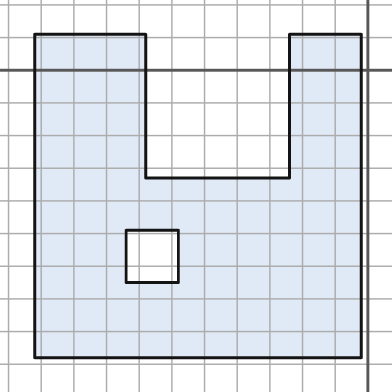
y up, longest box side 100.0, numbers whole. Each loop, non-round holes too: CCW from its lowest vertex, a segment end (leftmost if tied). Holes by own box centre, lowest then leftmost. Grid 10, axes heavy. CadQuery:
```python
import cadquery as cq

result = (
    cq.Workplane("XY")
    .moveTo(-102.0, -88.0)
    .lineTo(-2.0, -88.0)
    .lineTo(-2.0, 11.0)
    .lineTo(-24.0, 11.0)
    .lineTo(-24.0, -33.0)
    .lineTo(-68.0, -33.0)
    .lineTo(-68.0, 11.0)
    .lineTo(-102.0, 11.0)
    .close()
    .moveTo(-74.0, -65.0)
    .lineTo(-58.0, -65.0)
    .lineTo(-58.0, -49.0)
    .lineTo(-74.0, -49.0)
    .close()
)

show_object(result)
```